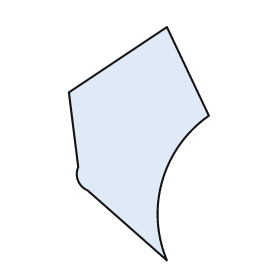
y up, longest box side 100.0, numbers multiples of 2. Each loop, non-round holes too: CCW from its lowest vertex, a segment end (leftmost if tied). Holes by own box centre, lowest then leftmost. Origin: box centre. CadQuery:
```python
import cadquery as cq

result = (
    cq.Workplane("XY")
    .moveTo(12.0, -50.0)
    .threePointArc((10.0, -16.0), (30.0, 12.0))
    .lineTo(12.0, 50.0)
    .lineTo(-30.0, 22.0)
    .lineTo(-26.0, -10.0)
    .threePointArc((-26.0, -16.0), (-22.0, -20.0))
    .close()
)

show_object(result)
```